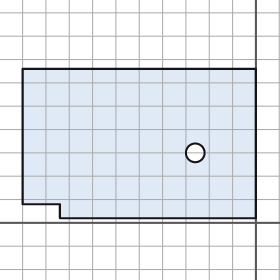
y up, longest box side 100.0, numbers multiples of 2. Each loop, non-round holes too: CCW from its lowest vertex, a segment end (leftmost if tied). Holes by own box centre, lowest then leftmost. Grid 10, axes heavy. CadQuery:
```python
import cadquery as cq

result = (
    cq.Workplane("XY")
    .moveTo(-84.0, 2.0)
    .lineTo(0.0, 2.0)
    .lineTo(0.0, 66.0)
    .lineTo(-100.0, 66.0)
    .lineTo(-100.0, 8.0)
    .lineTo(-84.0, 8.0)
    .close()
    .moveTo(-26.0, 30.0)
    .circle(4.0)
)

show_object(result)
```